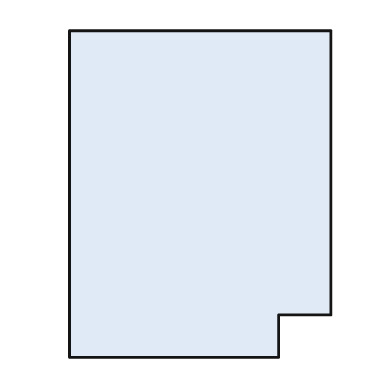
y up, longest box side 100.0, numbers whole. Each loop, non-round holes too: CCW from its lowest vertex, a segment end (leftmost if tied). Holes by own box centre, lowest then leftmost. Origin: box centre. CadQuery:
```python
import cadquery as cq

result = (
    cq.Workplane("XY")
    .moveTo(-40.0, -50.0)
    .lineTo(24.0, -50.0)
    .lineTo(24.0, -37.0)
    .lineTo(40.0, -37.0)
    .lineTo(40.0, 50.0)
    .lineTo(-40.0, 50.0)
    .close()
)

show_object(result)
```